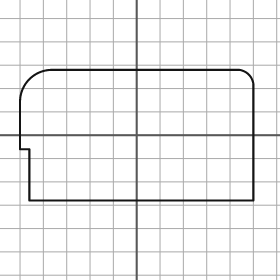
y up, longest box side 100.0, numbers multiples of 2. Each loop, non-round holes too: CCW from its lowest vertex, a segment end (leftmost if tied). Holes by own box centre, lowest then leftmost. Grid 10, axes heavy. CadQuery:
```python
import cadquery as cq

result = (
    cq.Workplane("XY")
    .moveTo(-46.0, -28.0)
    .lineTo(50.0, -28.0)
    .lineTo(50.0, 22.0)
    .threePointArc((48.0, 26.0), (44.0, 28.0))
    .lineTo(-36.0, 28.0)
    .threePointArc((-46.0, 24.0), (-50.0, 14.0))
    .lineTo(-50.0, -6.0)
    .lineTo(-46.0, -6.0)
    .close()
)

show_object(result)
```